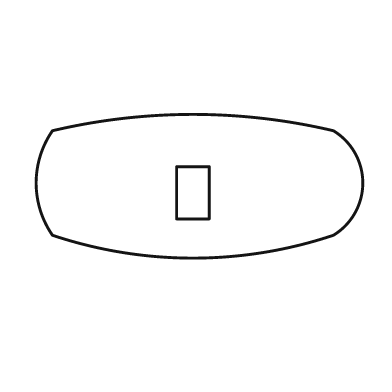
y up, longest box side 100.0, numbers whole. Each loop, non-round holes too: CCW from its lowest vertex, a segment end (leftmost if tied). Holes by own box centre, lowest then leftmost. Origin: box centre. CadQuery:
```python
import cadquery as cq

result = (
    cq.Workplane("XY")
    .moveTo(-45.0, -15.0)
    .threePointArc((-2.0, -22.0), (41.0, -15.0))
    .threePointArc((50.0, 1.0), (41.0, 17.0))
    .threePointArc((-2.0, 22.0), (-45.0, 17.0))
    .threePointArc((-50.0, 1.0), (-45.0, -15.0))
    .close()
    .moveTo(-7.0, -10.0)
    .lineTo(3.0, -10.0)
    .lineTo(3.0, 6.0)
    .lineTo(-7.0, 6.0)
    .close()
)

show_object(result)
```